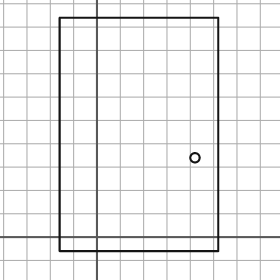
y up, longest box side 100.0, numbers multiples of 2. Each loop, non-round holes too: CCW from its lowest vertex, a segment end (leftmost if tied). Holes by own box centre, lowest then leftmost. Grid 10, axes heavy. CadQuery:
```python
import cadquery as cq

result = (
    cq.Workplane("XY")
    .moveTo(-16.0, -6.0)
    .lineTo(52.0, -6.0)
    .lineTo(52.0, 94.0)
    .lineTo(-16.0, 94.0)
    .close()
    .moveTo(42.0, 34.0)
    .circle(2.0)
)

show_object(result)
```